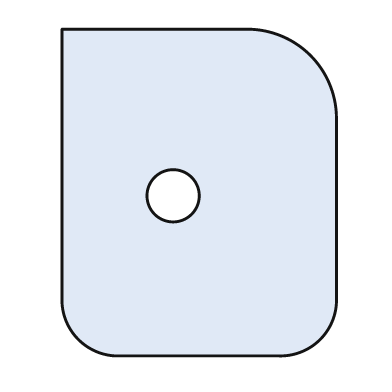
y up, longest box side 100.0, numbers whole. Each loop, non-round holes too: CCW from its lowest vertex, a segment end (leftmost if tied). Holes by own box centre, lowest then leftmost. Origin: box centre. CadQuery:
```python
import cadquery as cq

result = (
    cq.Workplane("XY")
    .moveTo(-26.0, -50.0)
    .lineTo(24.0, -50.0)
    .threePointArc((37.0, -45.0), (42.0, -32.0))
    .lineTo(42.0, 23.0)
    .threePointArc((34.0, 42.0), (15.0, 50.0))
    .lineTo(-42.0, 50.0)
    .lineTo(-42.0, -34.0)
    .threePointArc((-37.0, -45.0), (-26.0, -50.0))
    .close()
    .moveTo(-8.0, -1.0)
    .circle(8.0)
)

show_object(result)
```